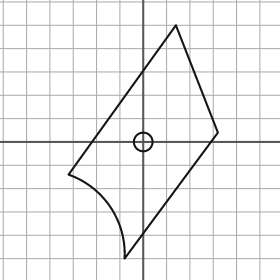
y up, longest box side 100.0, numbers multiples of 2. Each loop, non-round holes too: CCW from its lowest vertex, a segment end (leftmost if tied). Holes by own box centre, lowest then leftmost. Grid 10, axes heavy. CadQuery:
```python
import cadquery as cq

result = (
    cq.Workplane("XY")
    .moveTo(-8.0, -50.0)
    .lineTo(32.0, 4.0)
    .lineTo(14.0, 50.0)
    .lineTo(-32.0, -14.0)
    .threePointArc((-14.0, -28.0), (-8.0, -50.0))
    .close()
    .moveTo(0.0, 0.0)
    .circle(4.0)
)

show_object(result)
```